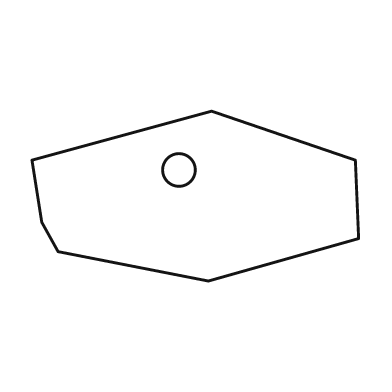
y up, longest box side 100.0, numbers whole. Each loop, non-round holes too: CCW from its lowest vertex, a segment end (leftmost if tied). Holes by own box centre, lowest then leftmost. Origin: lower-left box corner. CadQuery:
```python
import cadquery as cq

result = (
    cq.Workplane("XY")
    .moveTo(54.0, 0.0)
    .lineTo(100.0, 13.0)
    .lineTo(99.0, 37.0)
    .lineTo(55.0, 52.0)
    .lineTo(0.0, 37.0)
    .lineTo(3.0, 18.0)
    .lineTo(8.0, 9.0)
    .close()
    .moveTo(45.0, 34.0)
    .circle(5.0)
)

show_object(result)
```